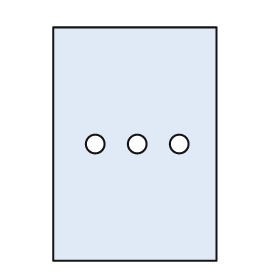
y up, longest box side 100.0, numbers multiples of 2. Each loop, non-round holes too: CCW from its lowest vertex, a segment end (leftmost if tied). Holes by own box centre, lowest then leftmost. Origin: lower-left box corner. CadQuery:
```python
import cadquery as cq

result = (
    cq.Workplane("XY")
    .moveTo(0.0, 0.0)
    .lineTo(70.0, 0.0)
    .lineTo(70.0, 100.0)
    .lineTo(0.0, 100.0)
    .close()
    .moveTo(18.0, 50.0)
    .circle(4.0)
    .moveTo(36.0, 50.0)
    .circle(4.0)
    .moveTo(54.0, 50.0)
    .circle(4.0)
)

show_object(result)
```